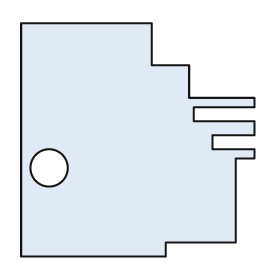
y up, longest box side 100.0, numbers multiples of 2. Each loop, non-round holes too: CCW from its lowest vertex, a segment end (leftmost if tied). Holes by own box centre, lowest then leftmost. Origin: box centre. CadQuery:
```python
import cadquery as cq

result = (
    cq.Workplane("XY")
    .moveTo(-50.0, -50.0)
    .lineTo(12.0, -50.0)
    .lineTo(12.0, -44.0)
    .lineTo(42.0, -44.0)
    .lineTo(42.0, -8.0)
    .lineTo(50.0, -8.0)
    .lineTo(50.0, -4.0)
    .lineTo(32.0, -4.0)
    .lineTo(32.0, 2.0)
    .lineTo(50.0, 2.0)
    .lineTo(50.0, 8.0)
    .lineTo(24.0, 8.0)
    .lineTo(24.0, 14.0)
    .lineTo(50.0, 14.0)
    .lineTo(50.0, 18.0)
    .lineTo(22.0, 18.0)
    .lineTo(22.0, 32.0)
    .lineTo(6.0, 32.0)
    .lineTo(6.0, 50.0)
    .lineTo(-50.0, 50.0)
    .close()
    .moveTo(-38.0, -12.0)
    .circle(8.0)
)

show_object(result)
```